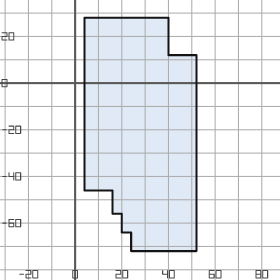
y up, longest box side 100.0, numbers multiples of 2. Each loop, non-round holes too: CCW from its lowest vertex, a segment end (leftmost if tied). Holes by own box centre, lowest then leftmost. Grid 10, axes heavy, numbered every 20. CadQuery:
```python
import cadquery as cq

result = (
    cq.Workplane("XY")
    .moveTo(24.0, -72.0)
    .lineTo(52.0, -72.0)
    .lineTo(52.0, 12.0)
    .lineTo(40.0, 12.0)
    .lineTo(40.0, 28.0)
    .lineTo(4.0, 28.0)
    .lineTo(4.0, -46.0)
    .lineTo(16.0, -46.0)
    .lineTo(16.0, -56.0)
    .lineTo(20.0, -56.0)
    .lineTo(20.0, -64.0)
    .lineTo(24.0, -64.0)
    .close()
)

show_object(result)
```